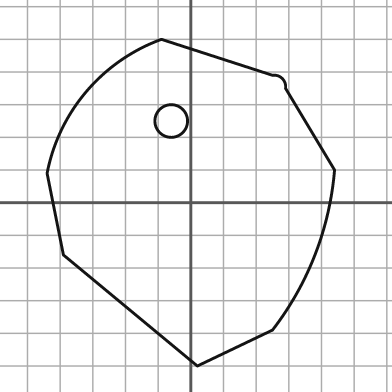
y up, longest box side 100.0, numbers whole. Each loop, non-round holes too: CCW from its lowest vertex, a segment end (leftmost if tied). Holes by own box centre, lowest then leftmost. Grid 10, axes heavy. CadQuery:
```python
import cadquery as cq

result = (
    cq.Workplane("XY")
    .moveTo(2.0, -50.0)
    .lineTo(25.0, -39.0)
    .threePointArc((38.0, -16.0), (44.0, 10.0))
    .lineTo(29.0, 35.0)
    .threePointArc((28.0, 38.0), (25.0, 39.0))
    .lineTo(-9.0, 50.0)
    .threePointArc((-32.0, 34.0), (-44.0, 9.0))
    .lineTo(-39.0, -16.0)
    .close()
    .moveTo(-6.0, 25.0)
    .circle(5.0)
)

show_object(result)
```